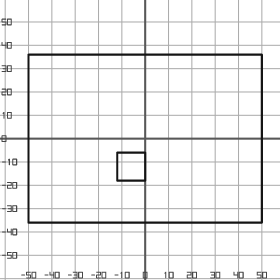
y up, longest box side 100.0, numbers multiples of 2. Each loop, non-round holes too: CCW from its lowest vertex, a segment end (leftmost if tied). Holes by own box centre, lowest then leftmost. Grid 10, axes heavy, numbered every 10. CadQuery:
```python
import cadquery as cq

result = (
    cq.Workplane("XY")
    .moveTo(-50.0, -36.0)
    .lineTo(50.0, -36.0)
    .lineTo(50.0, 36.0)
    .lineTo(-50.0, 36.0)
    .close()
    .moveTo(-12.0, -18.0)
    .lineTo(0.0, -18.0)
    .lineTo(0.0, -6.0)
    .lineTo(-12.0, -6.0)
    .close()
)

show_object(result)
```